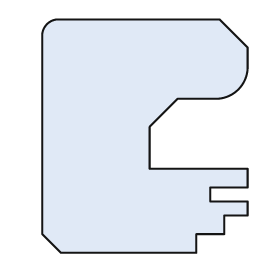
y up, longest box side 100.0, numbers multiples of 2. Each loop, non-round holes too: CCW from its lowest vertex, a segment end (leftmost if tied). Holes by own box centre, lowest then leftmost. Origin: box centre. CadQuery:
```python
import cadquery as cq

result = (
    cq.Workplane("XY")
    .moveTo(-36.0, -50.0)
    .lineTo(22.0, -50.0)
    .lineTo(22.0, -42.0)
    .lineTo(34.0, -42.0)
    .lineTo(34.0, -34.0)
    .lineTo(44.0, -34.0)
    .lineTo(44.0, -28.0)
    .lineTo(28.0, -28.0)
    .lineTo(28.0, -22.0)
    .lineTo(44.0, -22.0)
    .lineTo(44.0, -14.0)
    .lineTo(2.0, -14.0)
    .lineTo(2.0, 4.0)
    .lineTo(14.0, 16.0)
    .lineTo(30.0, 16.0)
    .threePointArc((40.0, 20.0), (44.0, 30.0))
    .lineTo(44.0, 38.0)
    .lineTo(32.0, 50.0)
    .lineTo(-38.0, 50.0)
    .threePointArc((-42.0, 48.0), (-44.0, 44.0))
    .lineTo(-44.0, -42.0)
    .close()
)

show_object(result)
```